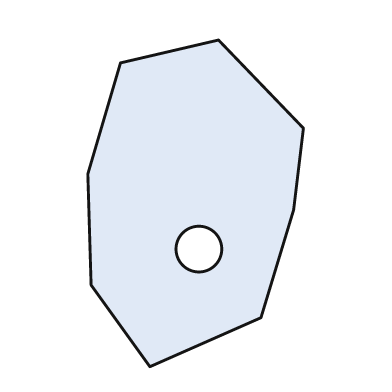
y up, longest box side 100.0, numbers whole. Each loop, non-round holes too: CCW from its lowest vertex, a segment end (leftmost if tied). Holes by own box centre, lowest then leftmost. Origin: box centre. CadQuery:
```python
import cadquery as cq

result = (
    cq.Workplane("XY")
    .moveTo(-14.0, -50.0)
    .lineTo(20.0, -35.0)
    .lineTo(30.0, -2.0)
    .lineTo(33.0, 23.0)
    .lineTo(7.0, 50.0)
    .lineTo(-23.0, 43.0)
    .lineTo(-33.0, 9.0)
    .lineTo(-32.0, -25.0)
    .close()
    .moveTo(1.0, -14.0)
    .circle(7.0)
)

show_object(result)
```